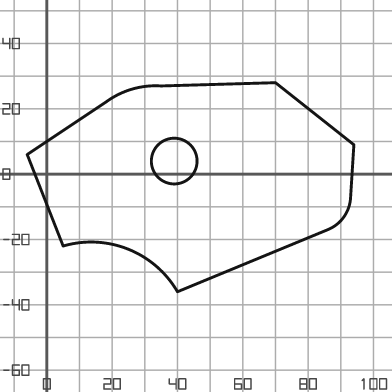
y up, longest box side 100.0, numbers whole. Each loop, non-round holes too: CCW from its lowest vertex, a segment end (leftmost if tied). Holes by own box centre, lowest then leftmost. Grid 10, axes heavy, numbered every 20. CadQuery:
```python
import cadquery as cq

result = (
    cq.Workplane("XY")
    .moveTo(40.0, -36.0)
    .lineTo(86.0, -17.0)
    .threePointArc((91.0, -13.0), (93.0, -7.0))
    .lineTo(94.0, 9.0)
    .lineTo(70.0, 28.0)
    .lineTo(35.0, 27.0)
    .threePointArc((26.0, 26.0), (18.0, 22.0))
    .lineTo(-6.0, 6.0)
    .lineTo(5.0, -22.0)
    .threePointArc((25.0, -23.0), (40.0, -36.0))
    .close()
    .moveTo(39.0, 4.0)
    .circle(7.0)
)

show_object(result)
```